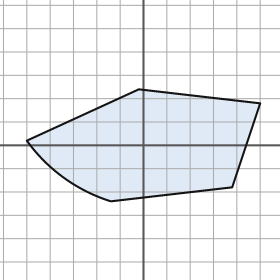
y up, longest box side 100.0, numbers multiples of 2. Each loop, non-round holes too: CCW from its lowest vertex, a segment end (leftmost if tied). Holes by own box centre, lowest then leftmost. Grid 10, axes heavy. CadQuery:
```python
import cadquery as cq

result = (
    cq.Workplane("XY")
    .moveTo(-14.0, -24.0)
    .lineTo(38.0, -18.0)
    .lineTo(50.0, 18.0)
    .lineTo(-2.0, 24.0)
    .lineTo(-50.0, 2.0)
    .threePointArc((-34.0, -14.0), (-14.0, -24.0))
    .close()
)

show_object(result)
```